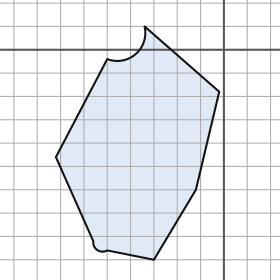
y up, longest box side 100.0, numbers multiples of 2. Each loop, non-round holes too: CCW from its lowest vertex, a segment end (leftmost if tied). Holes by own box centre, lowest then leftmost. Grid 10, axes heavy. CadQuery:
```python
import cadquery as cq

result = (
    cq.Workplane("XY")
    .moveTo(-30.0, -90.0)
    .lineTo(-12.0, -60.0)
    .lineTo(-2.0, -18.0)
    .lineTo(-34.0, 10.0)
    .threePointArc((-38.0, -2.0), (-50.0, -4.0))
    .lineTo(-72.0, -46.0)
    .lineTo(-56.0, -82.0)
    .threePointArc((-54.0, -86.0), (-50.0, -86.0))
    .close()
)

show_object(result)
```